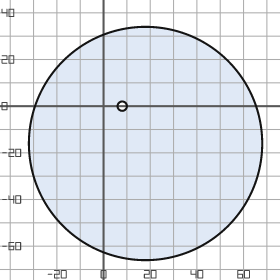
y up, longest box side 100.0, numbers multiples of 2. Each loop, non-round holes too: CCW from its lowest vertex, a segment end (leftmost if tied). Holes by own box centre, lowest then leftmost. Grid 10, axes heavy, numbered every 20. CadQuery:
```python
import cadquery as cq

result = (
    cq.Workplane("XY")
    .moveTo(18.0, -16.0)
    .circle(50.0)
    .moveTo(8.0, 0.0)
    .circle(2.0)
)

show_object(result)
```